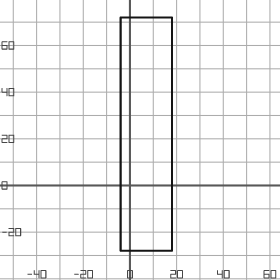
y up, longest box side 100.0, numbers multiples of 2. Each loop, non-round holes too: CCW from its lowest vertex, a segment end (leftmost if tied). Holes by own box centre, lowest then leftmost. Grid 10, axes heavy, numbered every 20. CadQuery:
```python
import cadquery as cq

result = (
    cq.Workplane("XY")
    .moveTo(-4.0, -28.0)
    .lineTo(18.0, -28.0)
    .lineTo(18.0, 72.0)
    .lineTo(-4.0, 72.0)
    .close()
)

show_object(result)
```